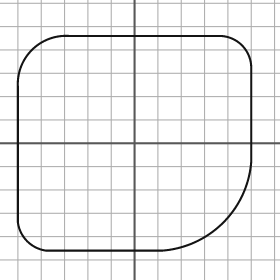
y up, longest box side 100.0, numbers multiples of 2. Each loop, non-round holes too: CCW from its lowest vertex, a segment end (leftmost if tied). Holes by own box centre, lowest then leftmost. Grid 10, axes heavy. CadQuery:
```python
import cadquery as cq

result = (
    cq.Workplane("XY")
    .moveTo(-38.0, -46.0)
    .lineTo(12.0, -46.0)
    .threePointArc((38.0, -34.0), (50.0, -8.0))
    .lineTo(50.0, 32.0)
    .threePointArc((46.0, 42.0), (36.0, 46.0))
    .lineTo(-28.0, 46.0)
    .threePointArc((-44.0, 40.0), (-50.0, 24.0))
    .lineTo(-50.0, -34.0)
    .threePointArc((-46.0, -42.0), (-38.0, -46.0))
    .close()
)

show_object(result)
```